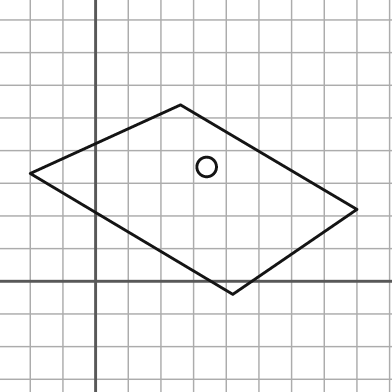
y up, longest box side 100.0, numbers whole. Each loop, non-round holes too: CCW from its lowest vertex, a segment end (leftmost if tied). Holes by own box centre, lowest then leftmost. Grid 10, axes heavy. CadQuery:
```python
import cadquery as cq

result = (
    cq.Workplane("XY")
    .moveTo(42.0, -4.0)
    .lineTo(80.0, 22.0)
    .lineTo(26.0, 54.0)
    .lineTo(-20.0, 33.0)
    .close()
    .moveTo(34.0, 35.0)
    .circle(3.0)
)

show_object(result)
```